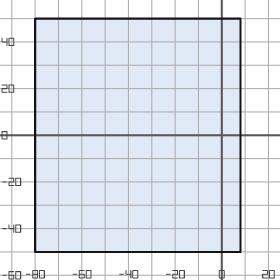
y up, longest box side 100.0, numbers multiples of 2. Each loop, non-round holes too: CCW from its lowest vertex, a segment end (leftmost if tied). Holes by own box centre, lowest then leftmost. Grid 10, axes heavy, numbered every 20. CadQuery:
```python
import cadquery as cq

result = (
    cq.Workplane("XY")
    .moveTo(-80.0, -50.0)
    .lineTo(8.0, -50.0)
    .lineTo(8.0, 50.0)
    .lineTo(-80.0, 50.0)
    .close()
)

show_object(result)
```